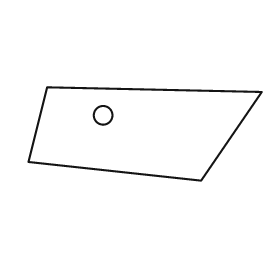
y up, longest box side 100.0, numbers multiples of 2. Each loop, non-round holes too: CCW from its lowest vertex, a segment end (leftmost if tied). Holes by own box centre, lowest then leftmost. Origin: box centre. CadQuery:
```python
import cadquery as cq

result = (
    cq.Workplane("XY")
    .moveTo(24.0, -20.0)
    .lineTo(50.0, 18.0)
    .lineTo(-42.0, 20.0)
    .lineTo(-50.0, -12.0)
    .close()
    .moveTo(-18.0, 8.0)
    .circle(4.0)
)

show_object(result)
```